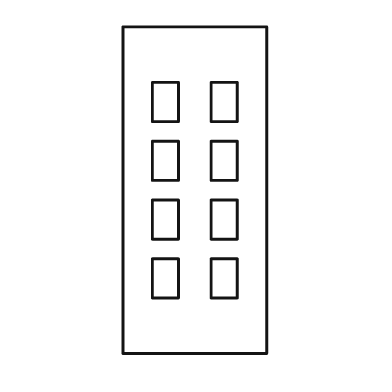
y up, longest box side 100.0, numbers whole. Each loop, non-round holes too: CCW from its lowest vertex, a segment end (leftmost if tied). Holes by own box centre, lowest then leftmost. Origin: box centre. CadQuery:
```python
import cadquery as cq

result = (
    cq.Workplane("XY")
    .moveTo(-22.0, -50.0)
    .lineTo(22.0, -50.0)
    .lineTo(22.0, 50.0)
    .lineTo(-22.0, 50.0)
    .close()
    .moveTo(-13.0, -33.0)
    .lineTo(-5.0, -33.0)
    .lineTo(-5.0, -21.0)
    .lineTo(-13.0, -21.0)
    .close()
    .moveTo(5.0, -33.0)
    .lineTo(13.0, -33.0)
    .lineTo(13.0, -21.0)
    .lineTo(5.0, -21.0)
    .close()
    .moveTo(-13.0, -15.0)
    .lineTo(-5.0, -15.0)
    .lineTo(-5.0, -3.0)
    .lineTo(-13.0, -3.0)
    .close()
    .moveTo(5.0, -15.0)
    .lineTo(13.0, -15.0)
    .lineTo(13.0, -3.0)
    .lineTo(5.0, -3.0)
    .close()
    .moveTo(-13.0, 3.0)
    .lineTo(-5.0, 3.0)
    .lineTo(-5.0, 15.0)
    .lineTo(-13.0, 15.0)
    .close()
    .moveTo(5.0, 3.0)
    .lineTo(13.0, 3.0)
    .lineTo(13.0, 15.0)
    .lineTo(5.0, 15.0)
    .close()
    .moveTo(-13.0, 21.0)
    .lineTo(-5.0, 21.0)
    .lineTo(-5.0, 33.0)
    .lineTo(-13.0, 33.0)
    .close()
    .moveTo(5.0, 21.0)
    .lineTo(13.0, 21.0)
    .lineTo(13.0, 33.0)
    .lineTo(5.0, 33.0)
    .close()
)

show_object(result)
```